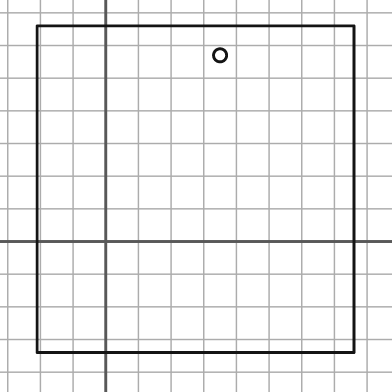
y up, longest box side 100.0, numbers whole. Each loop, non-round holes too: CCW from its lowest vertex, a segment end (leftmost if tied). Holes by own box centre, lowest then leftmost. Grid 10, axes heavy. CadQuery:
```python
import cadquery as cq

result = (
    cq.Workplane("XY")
    .moveTo(-21.0, -34.0)
    .lineTo(76.0, -34.0)
    .lineTo(76.0, 66.0)
    .lineTo(-21.0, 66.0)
    .close()
    .moveTo(35.0, 57.0)
    .circle(2.0)
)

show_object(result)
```